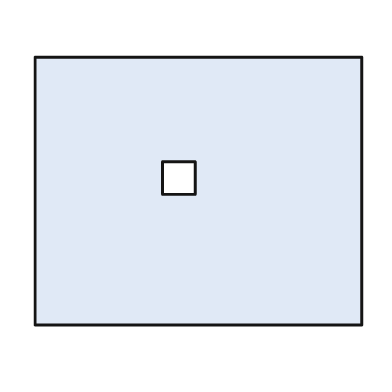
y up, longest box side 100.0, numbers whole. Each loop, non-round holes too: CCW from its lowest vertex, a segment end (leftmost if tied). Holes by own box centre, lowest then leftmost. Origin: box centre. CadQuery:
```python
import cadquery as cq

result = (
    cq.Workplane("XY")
    .moveTo(-50.0, -41.0)
    .lineTo(50.0, -41.0)
    .lineTo(50.0, 41.0)
    .lineTo(-50.0, 41.0)
    .close()
    .moveTo(-11.0, -1.0)
    .lineTo(-1.0, -1.0)
    .lineTo(-1.0, 9.0)
    .lineTo(-11.0, 9.0)
    .close()
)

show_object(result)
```